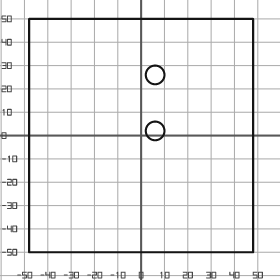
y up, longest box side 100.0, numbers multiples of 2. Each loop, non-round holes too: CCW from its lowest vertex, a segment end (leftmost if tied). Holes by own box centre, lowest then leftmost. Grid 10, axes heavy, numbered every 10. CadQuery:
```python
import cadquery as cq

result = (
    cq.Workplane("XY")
    .moveTo(-48.0, -50.0)
    .lineTo(48.0, -50.0)
    .lineTo(48.0, 50.0)
    .lineTo(-48.0, 50.0)
    .close()
    .moveTo(6.0, 2.0)
    .circle(4.0)
    .moveTo(6.0, 26.0)
    .circle(4.0)
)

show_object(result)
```